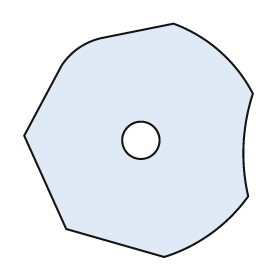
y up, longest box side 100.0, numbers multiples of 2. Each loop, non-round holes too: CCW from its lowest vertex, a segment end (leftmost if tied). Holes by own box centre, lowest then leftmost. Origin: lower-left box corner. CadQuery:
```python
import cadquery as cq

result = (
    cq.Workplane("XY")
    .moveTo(60.0, 0.0)
    .threePointArc((80.0, 10.0), (96.0, 26.0))
    .threePointArc((94.0, 48.0), (98.0, 70.0))
    .threePointArc((84.0, 88.0), (64.0, 100.0))
    .lineTo(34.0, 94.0)
    .threePointArc((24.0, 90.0), (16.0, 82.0))
    .lineTo(0.0, 52.0)
    .lineTo(18.0, 12.0)
    .close()
    .moveTo(50.0, 50.0)
    .circle(8.0)
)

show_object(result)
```